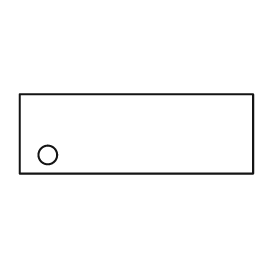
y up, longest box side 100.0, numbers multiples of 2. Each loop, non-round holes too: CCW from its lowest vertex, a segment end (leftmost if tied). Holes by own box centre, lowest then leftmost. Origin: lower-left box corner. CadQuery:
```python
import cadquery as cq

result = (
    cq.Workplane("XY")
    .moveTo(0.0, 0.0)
    .lineTo(100.0, 0.0)
    .lineTo(100.0, 34.0)
    .lineTo(0.0, 34.0)
    .close()
    .moveTo(12.0, 8.0)
    .circle(4.0)
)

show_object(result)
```